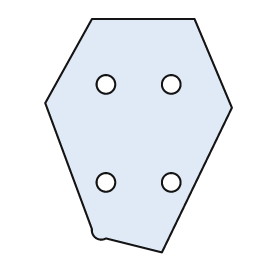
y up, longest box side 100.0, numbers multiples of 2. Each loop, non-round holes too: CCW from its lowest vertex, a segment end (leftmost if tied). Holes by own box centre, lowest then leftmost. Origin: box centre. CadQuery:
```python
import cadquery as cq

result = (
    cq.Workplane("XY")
    .moveTo(10.0, -50.0)
    .lineTo(40.0, 12.0)
    .lineTo(24.0, 50.0)
    .lineTo(-20.0, 50.0)
    .lineTo(-40.0, 14.0)
    .lineTo(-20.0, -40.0)
    .threePointArc((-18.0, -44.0), (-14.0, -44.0))
    .close()
    .moveTo(-14.0, -20.0)
    .circle(4.0)
    .moveTo(14.0, -20.0)
    .circle(4.0)
    .moveTo(-14.0, 22.0)
    .circle(4.0)
    .moveTo(14.0, 22.0)
    .circle(4.0)
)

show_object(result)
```